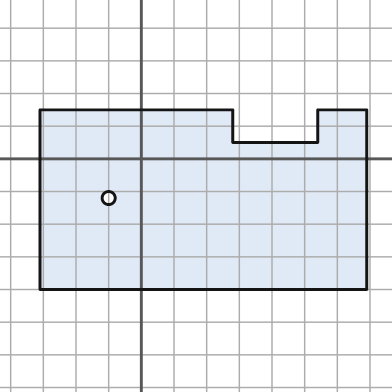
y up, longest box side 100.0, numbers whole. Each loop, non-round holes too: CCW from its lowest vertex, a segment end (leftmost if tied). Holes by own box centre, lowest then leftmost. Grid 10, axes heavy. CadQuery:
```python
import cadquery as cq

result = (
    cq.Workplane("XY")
    .moveTo(-31.0, -40.0)
    .lineTo(69.0, -40.0)
    .lineTo(69.0, 15.0)
    .lineTo(54.0, 15.0)
    .lineTo(54.0, 5.0)
    .lineTo(28.0, 5.0)
    .lineTo(28.0, 15.0)
    .lineTo(-31.0, 15.0)
    .close()
    .moveTo(-10.0, -12.0)
    .circle(2.0)
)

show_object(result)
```